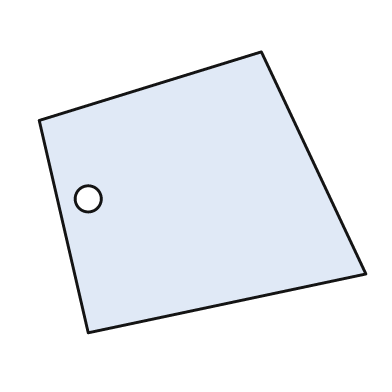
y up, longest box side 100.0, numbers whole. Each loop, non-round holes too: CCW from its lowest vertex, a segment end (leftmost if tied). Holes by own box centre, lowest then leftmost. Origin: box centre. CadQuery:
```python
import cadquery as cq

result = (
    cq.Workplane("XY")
    .moveTo(-35.0, -43.0)
    .lineTo(50.0, -25.0)
    .lineTo(18.0, 43.0)
    .lineTo(-50.0, 22.0)
    .close()
    .moveTo(-35.0, -2.0)
    .circle(4.0)
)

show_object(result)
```